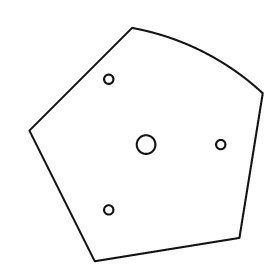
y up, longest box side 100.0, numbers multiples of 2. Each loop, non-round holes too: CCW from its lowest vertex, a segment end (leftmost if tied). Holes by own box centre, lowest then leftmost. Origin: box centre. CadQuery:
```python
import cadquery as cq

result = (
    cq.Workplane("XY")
    .moveTo(-22.0, -50.0)
    .lineTo(40.0, -40.0)
    .lineTo(50.0, 22.0)
    .threePointArc((24.0, 40.0), (-6.0, 50.0))
    .lineTo(-50.0, 6.0)
    .close()
    .moveTo(-16.0, -28.0)
    .circle(2.0)
    .moveTo(0.0, 0.0)
    .circle(4.0)
    .moveTo(32.0, 0.0)
    .circle(2.0)
    .moveTo(-16.0, 28.0)
    .circle(2.0)
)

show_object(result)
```